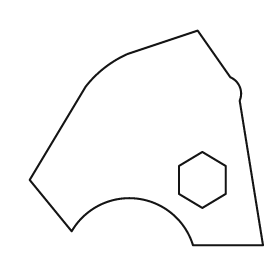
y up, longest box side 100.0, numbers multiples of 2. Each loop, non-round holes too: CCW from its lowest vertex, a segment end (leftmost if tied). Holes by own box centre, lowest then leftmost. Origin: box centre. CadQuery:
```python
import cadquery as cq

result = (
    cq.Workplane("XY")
    .moveTo(20.0, -46.0)
    .lineTo(50.0, -46.0)
    .lineTo(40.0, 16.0)
    .threePointArc((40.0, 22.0), (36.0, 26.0))
    .lineTo(22.0, 46.0)
    .lineTo(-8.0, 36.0)
    .threePointArc((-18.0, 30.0), (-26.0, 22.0))
    .lineTo(-50.0, -18.0)
    .lineTo(-32.0, -40.0)
    .threePointArc((-4.0, -26.0), (20.0, -46.0))
    .close()
    .moveTo(24.0, -30.0)
    .lineTo(34.0, -24.0)
    .lineTo(34.0, -12.0)
    .lineTo(24.0, -6.0)
    .lineTo(14.0, -12.0)
    .lineTo(14.0, -24.0)
    .close()
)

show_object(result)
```